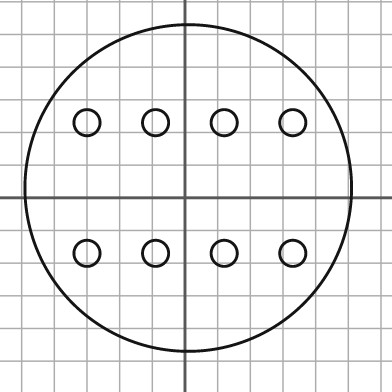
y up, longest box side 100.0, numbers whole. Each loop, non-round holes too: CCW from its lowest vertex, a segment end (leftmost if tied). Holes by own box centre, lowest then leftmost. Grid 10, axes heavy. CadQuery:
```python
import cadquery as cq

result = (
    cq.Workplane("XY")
    .moveTo(1.0, 3.0)
    .circle(50.0)
    .moveTo(-30.0, -17.0)
    .circle(4.0)
    .moveTo(-9.0, -17.0)
    .circle(4.0)
    .moveTo(12.0, -17.0)
    .circle(4.0)
    .moveTo(33.0, -17.0)
    .circle(4.0)
    .moveTo(-30.0, 23.0)
    .circle(4.0)
    .moveTo(-9.0, 23.0)
    .circle(4.0)
    .moveTo(12.0, 23.0)
    .circle(4.0)
    .moveTo(33.0, 23.0)
    .circle(4.0)
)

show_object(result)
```